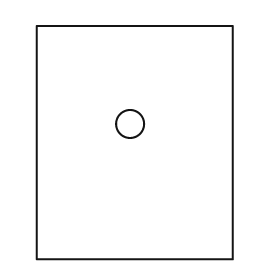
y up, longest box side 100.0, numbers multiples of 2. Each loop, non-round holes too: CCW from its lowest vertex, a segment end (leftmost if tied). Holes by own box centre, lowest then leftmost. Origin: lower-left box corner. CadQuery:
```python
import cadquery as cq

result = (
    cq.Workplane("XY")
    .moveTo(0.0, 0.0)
    .lineTo(84.0, 0.0)
    .lineTo(84.0, 100.0)
    .lineTo(0.0, 100.0)
    .close()
    .moveTo(40.0, 58.0)
    .circle(6.0)
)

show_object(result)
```